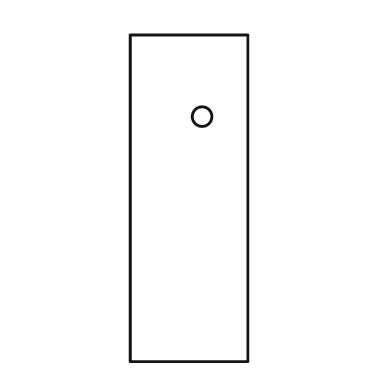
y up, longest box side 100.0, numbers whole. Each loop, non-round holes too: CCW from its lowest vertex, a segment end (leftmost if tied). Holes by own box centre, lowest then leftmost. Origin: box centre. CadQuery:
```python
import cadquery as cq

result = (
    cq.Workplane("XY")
    .moveTo(-18.0, -50.0)
    .lineTo(18.0, -50.0)
    .lineTo(18.0, 50.0)
    .lineTo(-18.0, 50.0)
    .close()
    .moveTo(4.0, 25.0)
    .circle(3.0)
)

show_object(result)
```